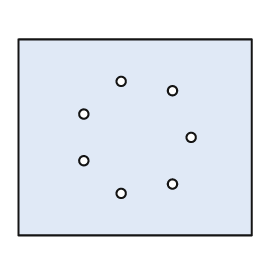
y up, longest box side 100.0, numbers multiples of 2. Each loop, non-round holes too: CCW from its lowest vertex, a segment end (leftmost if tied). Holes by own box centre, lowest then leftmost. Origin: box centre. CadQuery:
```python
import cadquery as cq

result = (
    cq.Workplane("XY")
    .moveTo(-50.0, -42.0)
    .lineTo(50.0, -42.0)
    .lineTo(50.0, 42.0)
    .lineTo(-50.0, 42.0)
    .close()
    .moveTo(-6.0, -24.0)
    .circle(2.0)
    .moveTo(16.0, -20.0)
    .circle(2.0)
    .moveTo(-22.0, -10.0)
    .circle(2.0)
    .moveTo(24.0, 0.0)
    .circle(2.0)
    .moveTo(-22.0, 10.0)
    .circle(2.0)
    .moveTo(16.0, 20.0)
    .circle(2.0)
    .moveTo(-6.0, 24.0)
    .circle(2.0)
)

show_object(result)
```